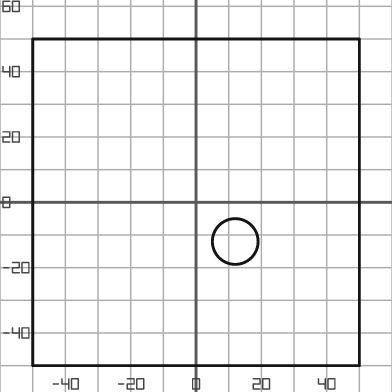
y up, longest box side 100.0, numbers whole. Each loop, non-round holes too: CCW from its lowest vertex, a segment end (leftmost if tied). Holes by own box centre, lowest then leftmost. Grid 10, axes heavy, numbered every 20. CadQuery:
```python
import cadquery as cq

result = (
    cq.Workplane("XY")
    .moveTo(-50.0, -50.0)
    .lineTo(50.0, -50.0)
    .lineTo(50.0, 50.0)
    .lineTo(-50.0, 50.0)
    .close()
    .moveTo(12.0, -12.0)
    .circle(7.0)
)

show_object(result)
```